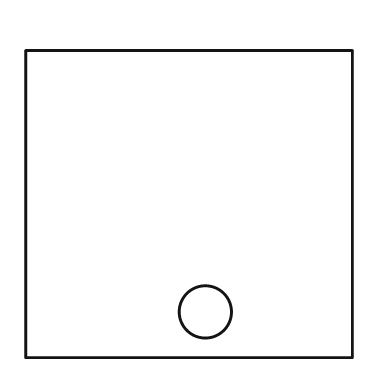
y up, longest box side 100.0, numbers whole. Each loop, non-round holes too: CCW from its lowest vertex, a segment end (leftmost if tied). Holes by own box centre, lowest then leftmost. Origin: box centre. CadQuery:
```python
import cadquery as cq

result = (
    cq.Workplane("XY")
    .moveTo(-50.0, -47.0)
    .lineTo(50.0, -47.0)
    .lineTo(50.0, 47.0)
    .lineTo(-50.0, 47.0)
    .close()
    .moveTo(5.0, -33.0)
    .circle(8.0)
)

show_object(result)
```